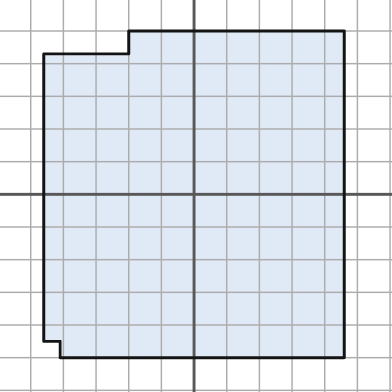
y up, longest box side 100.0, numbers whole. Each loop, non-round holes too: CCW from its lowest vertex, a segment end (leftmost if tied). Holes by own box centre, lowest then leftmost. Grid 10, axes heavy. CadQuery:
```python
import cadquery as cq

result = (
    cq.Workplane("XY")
    .moveTo(-41.0, -50.0)
    .lineTo(46.0, -50.0)
    .lineTo(46.0, 50.0)
    .lineTo(-20.0, 50.0)
    .lineTo(-20.0, 43.0)
    .lineTo(-46.0, 43.0)
    .lineTo(-46.0, -45.0)
    .lineTo(-41.0, -45.0)
    .close()
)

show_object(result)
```